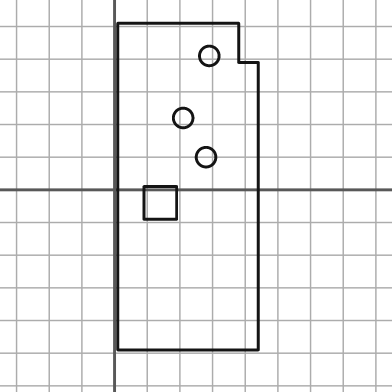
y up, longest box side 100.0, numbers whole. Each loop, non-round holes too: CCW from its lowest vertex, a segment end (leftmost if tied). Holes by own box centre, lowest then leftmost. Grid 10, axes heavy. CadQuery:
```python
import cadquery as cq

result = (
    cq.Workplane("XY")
    .moveTo(1.0, -49.0)
    .lineTo(44.0, -49.0)
    .lineTo(44.0, 39.0)
    .lineTo(38.0, 39.0)
    .lineTo(38.0, 51.0)
    .lineTo(1.0, 51.0)
    .close()
    .moveTo(9.0, -9.0)
    .lineTo(19.0, -9.0)
    .lineTo(19.0, 1.0)
    .lineTo(9.0, 1.0)
    .close()
    .moveTo(28.0, 10.0)
    .circle(3.0)
    .moveTo(21.0, 22.0)
    .circle(3.0)
    .moveTo(29.0, 41.0)
    .circle(3.0)
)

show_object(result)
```